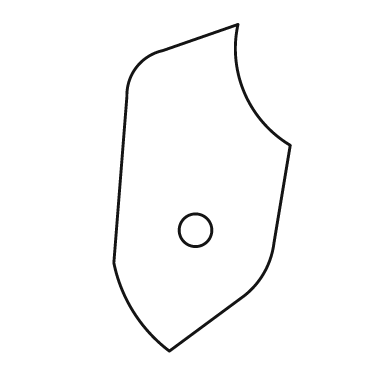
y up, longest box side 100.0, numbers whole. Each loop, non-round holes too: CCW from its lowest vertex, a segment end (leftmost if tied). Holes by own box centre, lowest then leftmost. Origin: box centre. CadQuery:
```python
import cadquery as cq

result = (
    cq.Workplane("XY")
    .moveTo(-10.0, -50.0)
    .lineTo(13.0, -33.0)
    .threePointArc((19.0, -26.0), (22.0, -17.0))
    .lineTo(27.0, 13.0)
    .threePointArc((13.0, 29.0), (11.0, 50.0))
    .lineTo(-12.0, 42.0)
    .threePointArc((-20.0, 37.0), (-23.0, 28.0))
    .lineTo(-27.0, -23.0)
    .threePointArc((-21.0, -38.0), (-10.0, -50.0))
    .close()
    .moveTo(-2.0, -13.0)
    .circle(5.0)
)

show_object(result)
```